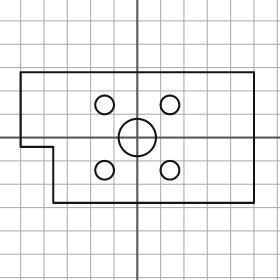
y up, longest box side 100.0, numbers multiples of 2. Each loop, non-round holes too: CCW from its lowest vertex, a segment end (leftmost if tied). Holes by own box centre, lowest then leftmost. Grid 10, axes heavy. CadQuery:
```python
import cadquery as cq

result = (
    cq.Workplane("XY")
    .moveTo(-36.0, -28.0)
    .lineTo(50.0, -28.0)
    .lineTo(50.0, 28.0)
    .lineTo(-50.0, 28.0)
    .lineTo(-50.0, -4.0)
    .lineTo(-36.0, -4.0)
    .close()
    .moveTo(-14.0, -14.0)
    .circle(4.0)
    .moveTo(14.0, -14.0)
    .circle(4.0)
    .moveTo(0.0, 0.0)
    .circle(8.0)
    .moveTo(-14.0, 14.0)
    .circle(4.0)
    .moveTo(14.0, 14.0)
    .circle(4.0)
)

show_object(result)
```